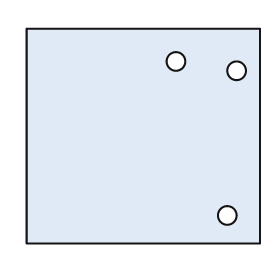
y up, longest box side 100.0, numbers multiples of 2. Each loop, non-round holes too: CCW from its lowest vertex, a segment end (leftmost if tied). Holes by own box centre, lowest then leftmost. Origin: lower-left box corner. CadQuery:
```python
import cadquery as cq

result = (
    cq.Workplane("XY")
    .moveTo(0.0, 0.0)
    .lineTo(100.0, 0.0)
    .lineTo(100.0, 92.0)
    .lineTo(0.0, 92.0)
    .close()
    .moveTo(86.0, 12.0)
    .circle(4.0)
    .moveTo(90.0, 74.0)
    .circle(4.0)
    .moveTo(64.0, 78.0)
    .circle(4.0)
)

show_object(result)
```